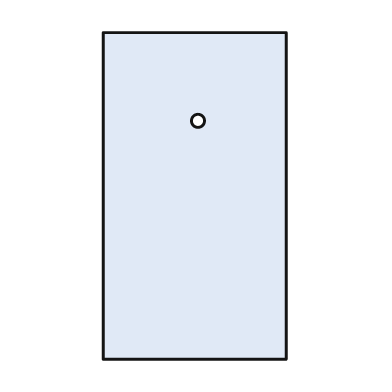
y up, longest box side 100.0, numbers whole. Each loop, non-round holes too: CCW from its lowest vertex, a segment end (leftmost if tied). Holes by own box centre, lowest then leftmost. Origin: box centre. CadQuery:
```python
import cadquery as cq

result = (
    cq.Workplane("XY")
    .moveTo(-28.0, -50.0)
    .lineTo(28.0, -50.0)
    .lineTo(28.0, 50.0)
    .lineTo(-28.0, 50.0)
    .close()
    .moveTo(1.0, 23.0)
    .circle(2.0)
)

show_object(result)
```